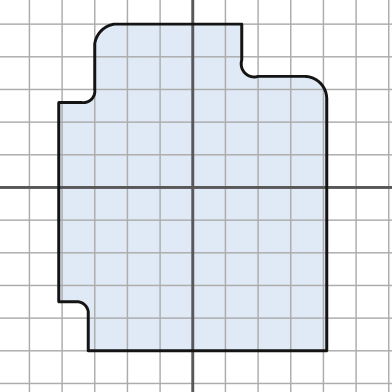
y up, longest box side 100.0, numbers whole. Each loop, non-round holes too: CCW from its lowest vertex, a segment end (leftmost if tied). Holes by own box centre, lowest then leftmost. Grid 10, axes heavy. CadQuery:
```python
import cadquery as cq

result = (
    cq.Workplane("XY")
    .moveTo(-32.0, -50.0)
    .lineTo(41.0, -50.0)
    .lineTo(41.0, 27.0)
    .threePointArc((39.0, 32.0), (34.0, 34.0))
    .lineTo(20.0, 34.0)
    .threePointArc((16.0, 35.0), (15.0, 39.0))
    .lineTo(15.0, 50.0)
    .lineTo(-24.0, 50.0)
    .threePointArc((-28.0, 48.0), (-30.0, 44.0))
    .lineTo(-30.0, 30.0)
    .threePointArc((-31.0, 27.0), (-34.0, 26.0))
    .lineTo(-41.0, 26.0)
    .lineTo(-41.0, -35.0)
    .lineTo(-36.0, -35.0)
    .threePointArc((-33.0, -36.0), (-32.0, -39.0))
    .close()
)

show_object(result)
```